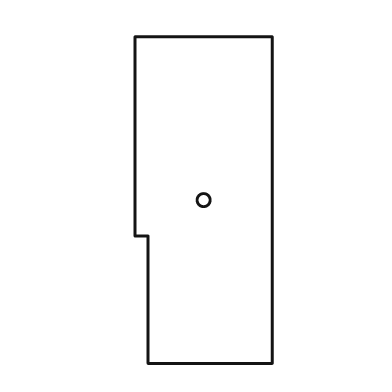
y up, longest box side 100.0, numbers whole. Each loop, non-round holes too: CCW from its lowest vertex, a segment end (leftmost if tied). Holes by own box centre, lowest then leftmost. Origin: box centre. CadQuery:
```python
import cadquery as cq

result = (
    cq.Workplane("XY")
    .moveTo(-17.0, -50.0)
    .lineTo(21.0, -50.0)
    .lineTo(21.0, 50.0)
    .lineTo(-21.0, 50.0)
    .lineTo(-21.0, -11.0)
    .lineTo(-17.0, -11.0)
    .close()
    .moveTo(0.0, 0.0)
    .circle(2.0)
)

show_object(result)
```